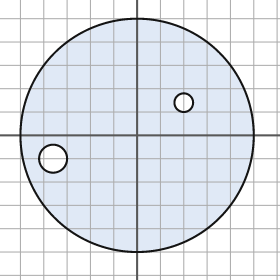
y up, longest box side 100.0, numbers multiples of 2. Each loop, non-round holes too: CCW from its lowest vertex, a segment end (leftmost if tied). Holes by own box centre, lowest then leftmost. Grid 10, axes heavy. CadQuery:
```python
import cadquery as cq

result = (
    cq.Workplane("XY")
    .moveTo(0.0, 0.0)
    .circle(50.0)
    .moveTo(-36.0, -10.0)
    .circle(6.0)
    .moveTo(20.0, 14.0)
    .circle(4.0)
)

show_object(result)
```